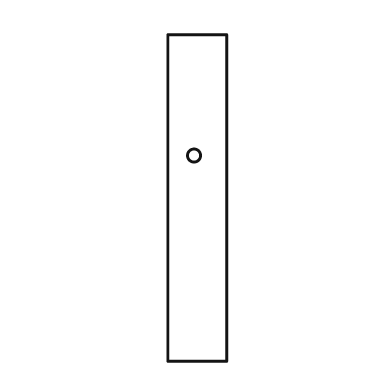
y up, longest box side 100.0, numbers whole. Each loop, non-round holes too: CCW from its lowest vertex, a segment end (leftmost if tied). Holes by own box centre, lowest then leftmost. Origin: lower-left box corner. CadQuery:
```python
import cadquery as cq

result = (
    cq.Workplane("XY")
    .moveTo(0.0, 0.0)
    .lineTo(18.0, 0.0)
    .lineTo(18.0, 100.0)
    .lineTo(0.0, 100.0)
    .close()
    .moveTo(8.0, 63.0)
    .circle(2.0)
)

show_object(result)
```